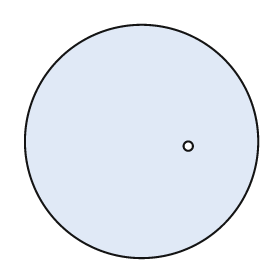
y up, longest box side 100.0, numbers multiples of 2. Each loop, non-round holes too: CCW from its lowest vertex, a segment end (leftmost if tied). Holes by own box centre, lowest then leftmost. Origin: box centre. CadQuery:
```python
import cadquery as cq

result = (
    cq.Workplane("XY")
    .moveTo(0.0, 0.0)
    .circle(50.0)
    .moveTo(20.0, -2.0)
    .circle(2.0)
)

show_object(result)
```